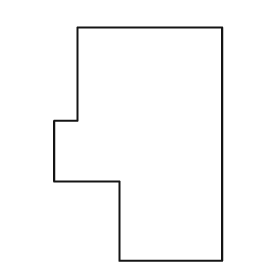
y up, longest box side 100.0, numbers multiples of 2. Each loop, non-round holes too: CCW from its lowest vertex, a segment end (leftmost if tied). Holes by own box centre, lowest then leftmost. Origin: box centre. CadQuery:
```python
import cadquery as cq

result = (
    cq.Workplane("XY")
    .moveTo(-8.0, -50.0)
    .lineTo(36.0, -50.0)
    .lineTo(36.0, 50.0)
    .lineTo(-26.0, 50.0)
    .lineTo(-26.0, 10.0)
    .lineTo(-36.0, 10.0)
    .lineTo(-36.0, -16.0)
    .lineTo(-8.0, -16.0)
    .close()
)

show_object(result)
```